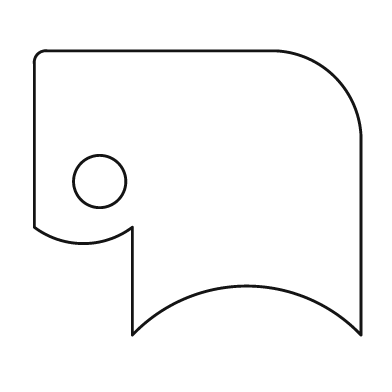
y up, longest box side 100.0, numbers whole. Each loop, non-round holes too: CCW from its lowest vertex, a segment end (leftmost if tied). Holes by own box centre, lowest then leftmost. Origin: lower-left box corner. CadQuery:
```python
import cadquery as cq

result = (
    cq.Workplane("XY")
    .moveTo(30.0, 0.0)
    .threePointArc((65.0, 15.0), (100.0, 0.0))
    .lineTo(100.0, 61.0)
    .threePointArc((92.0, 79.0), (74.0, 87.0))
    .lineTo(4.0, 87.0)
    .threePointArc((1.0, 86.0), (0.0, 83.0))
    .lineTo(0.0, 33.0)
    .threePointArc((15.0, 28.0), (30.0, 33.0))
    .close()
    .moveTo(20.0, 47.0)
    .circle(8.0)
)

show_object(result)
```